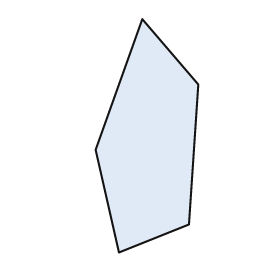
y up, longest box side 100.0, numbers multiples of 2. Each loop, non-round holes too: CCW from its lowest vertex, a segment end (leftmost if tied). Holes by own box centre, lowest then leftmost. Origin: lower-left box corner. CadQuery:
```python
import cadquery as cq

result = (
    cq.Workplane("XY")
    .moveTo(10.0, 0.0)
    .lineTo(40.0, 12.0)
    .lineTo(44.0, 72.0)
    .lineTo(20.0, 100.0)
    .lineTo(0.0, 44.0)
    .close()
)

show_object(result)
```